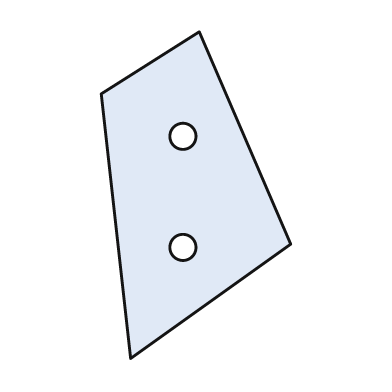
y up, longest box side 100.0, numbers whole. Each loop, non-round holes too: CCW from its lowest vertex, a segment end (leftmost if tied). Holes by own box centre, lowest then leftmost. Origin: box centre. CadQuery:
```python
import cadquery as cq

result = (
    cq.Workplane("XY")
    .moveTo(-20.0, -50.0)
    .lineTo(29.0, -15.0)
    .lineTo(1.0, 50.0)
    .lineTo(-29.0, 31.0)
    .close()
    .moveTo(-4.0, -16.0)
    .circle(4.0)
    .moveTo(-4.0, 18.0)
    .circle(4.0)
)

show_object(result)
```